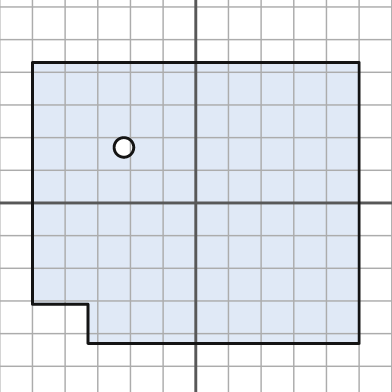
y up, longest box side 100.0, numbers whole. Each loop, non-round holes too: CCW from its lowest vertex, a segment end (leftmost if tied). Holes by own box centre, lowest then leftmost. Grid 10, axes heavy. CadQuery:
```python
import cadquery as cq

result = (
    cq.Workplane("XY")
    .moveTo(-33.0, -43.0)
    .lineTo(50.0, -43.0)
    .lineTo(50.0, 43.0)
    .lineTo(-50.0, 43.0)
    .lineTo(-50.0, -31.0)
    .lineTo(-33.0, -31.0)
    .close()
    .moveTo(-22.0, 17.0)
    .circle(3.0)
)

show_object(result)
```